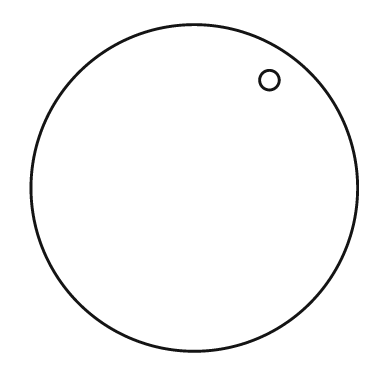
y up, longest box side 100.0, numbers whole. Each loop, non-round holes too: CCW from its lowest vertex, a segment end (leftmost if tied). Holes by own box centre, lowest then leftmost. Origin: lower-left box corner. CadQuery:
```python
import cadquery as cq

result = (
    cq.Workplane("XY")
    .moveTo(50.0, 50.0)
    .circle(50.0)
    .moveTo(73.0, 83.0)
    .circle(3.0)
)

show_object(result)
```